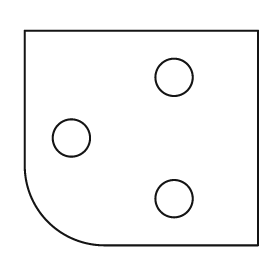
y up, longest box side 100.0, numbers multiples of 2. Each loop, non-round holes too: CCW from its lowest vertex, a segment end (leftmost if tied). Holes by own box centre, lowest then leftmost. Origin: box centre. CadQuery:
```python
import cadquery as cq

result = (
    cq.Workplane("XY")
    .moveTo(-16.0, -46.0)
    .lineTo(50.0, -46.0)
    .lineTo(50.0, 46.0)
    .lineTo(-50.0, 46.0)
    .lineTo(-50.0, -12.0)
    .threePointArc((-40.0, -36.0), (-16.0, -46.0))
    .close()
    .moveTo(14.0, -26.0)
    .circle(8.0)
    .moveTo(-30.0, 0.0)
    .circle(8.0)
    .moveTo(14.0, 26.0)
    .circle(8.0)
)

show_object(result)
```